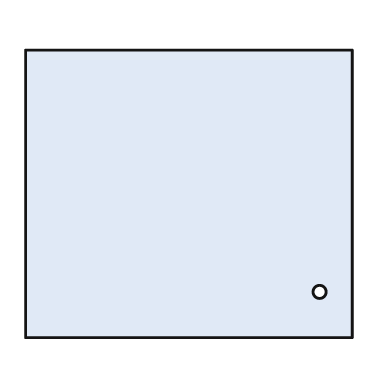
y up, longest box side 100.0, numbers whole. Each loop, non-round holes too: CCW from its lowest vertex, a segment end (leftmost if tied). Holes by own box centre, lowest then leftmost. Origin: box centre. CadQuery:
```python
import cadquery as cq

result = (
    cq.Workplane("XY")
    .moveTo(-50.0, -44.0)
    .lineTo(50.0, -44.0)
    .lineTo(50.0, 44.0)
    .lineTo(-50.0, 44.0)
    .close()
    .moveTo(40.0, -30.0)
    .circle(2.0)
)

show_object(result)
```